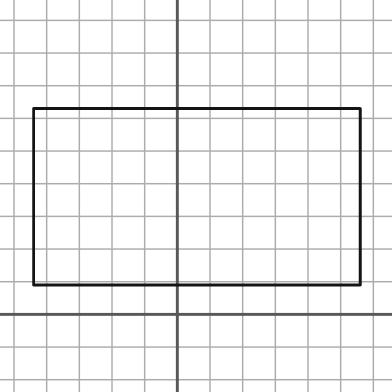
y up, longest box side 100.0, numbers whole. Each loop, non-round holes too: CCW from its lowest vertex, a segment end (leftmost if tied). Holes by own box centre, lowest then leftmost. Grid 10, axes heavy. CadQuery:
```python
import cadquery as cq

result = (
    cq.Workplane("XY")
    .moveTo(-44.0, 9.0)
    .lineTo(56.0, 9.0)
    .lineTo(56.0, 63.0)
    .lineTo(-44.0, 63.0)
    .close()
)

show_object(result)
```